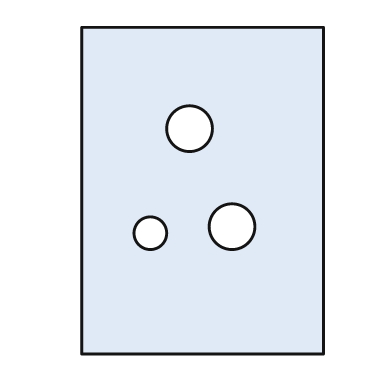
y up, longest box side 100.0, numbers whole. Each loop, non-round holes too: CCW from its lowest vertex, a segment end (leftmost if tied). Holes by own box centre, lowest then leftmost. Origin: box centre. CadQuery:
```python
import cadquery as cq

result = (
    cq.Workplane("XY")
    .moveTo(-37.0, -50.0)
    .lineTo(37.0, -50.0)
    .lineTo(37.0, 50.0)
    .lineTo(-37.0, 50.0)
    .close()
    .moveTo(-16.0, -13.0)
    .circle(5.0)
    .moveTo(9.0, -11.0)
    .circle(7.0)
    .moveTo(-4.0, 19.0)
    .circle(7.0)
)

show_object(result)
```